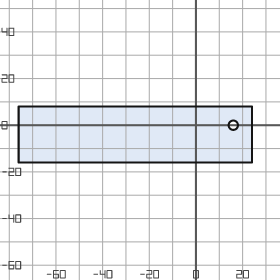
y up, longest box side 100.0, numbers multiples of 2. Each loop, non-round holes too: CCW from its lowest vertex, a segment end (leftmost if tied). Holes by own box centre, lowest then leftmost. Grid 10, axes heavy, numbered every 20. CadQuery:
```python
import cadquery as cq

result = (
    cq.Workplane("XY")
    .moveTo(-76.0, -16.0)
    .lineTo(24.0, -16.0)
    .lineTo(24.0, 8.0)
    .lineTo(-76.0, 8.0)
    .close()
    .moveTo(16.0, 0.0)
    .circle(2.0)
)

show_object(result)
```